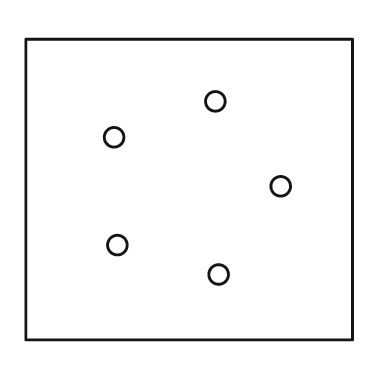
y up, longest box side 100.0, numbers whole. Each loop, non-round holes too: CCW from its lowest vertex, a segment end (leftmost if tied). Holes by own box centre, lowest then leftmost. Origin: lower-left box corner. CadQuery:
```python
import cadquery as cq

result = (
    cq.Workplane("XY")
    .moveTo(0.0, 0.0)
    .lineTo(100.0, 0.0)
    .lineTo(100.0, 92.0)
    .lineTo(0.0, 92.0)
    .close()
    .moveTo(59.0, 20.0)
    .circle(3.0)
    .moveTo(28.0, 29.0)
    .circle(3.0)
    .moveTo(78.0, 47.0)
    .circle(3.0)
    .moveTo(27.0, 62.0)
    .circle(3.0)
    .moveTo(58.0, 73.0)
    .circle(3.0)
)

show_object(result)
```